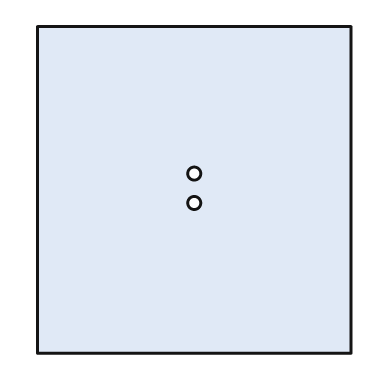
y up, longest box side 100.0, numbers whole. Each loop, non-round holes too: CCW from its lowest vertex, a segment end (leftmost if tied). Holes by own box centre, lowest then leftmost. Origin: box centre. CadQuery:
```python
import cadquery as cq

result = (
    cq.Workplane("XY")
    .moveTo(-48.0, -50.0)
    .lineTo(48.0, -50.0)
    .lineTo(48.0, 50.0)
    .lineTo(-48.0, 50.0)
    .close()
    .moveTo(0.0, -4.0)
    .circle(2.0)
    .moveTo(0.0, 5.0)
    .circle(2.0)
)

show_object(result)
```